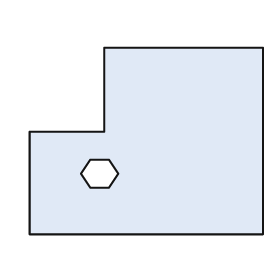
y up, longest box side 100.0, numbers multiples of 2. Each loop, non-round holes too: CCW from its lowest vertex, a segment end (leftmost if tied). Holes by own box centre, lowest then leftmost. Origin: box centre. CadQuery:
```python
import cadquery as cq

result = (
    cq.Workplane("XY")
    .moveTo(-50.0, -40.0)
    .lineTo(50.0, -40.0)
    .lineTo(50.0, 40.0)
    .lineTo(-18.0, 40.0)
    .lineTo(-18.0, 4.0)
    .lineTo(-50.0, 4.0)
    .close()
    .moveTo(-24.0, -20.0)
    .lineTo(-16.0, -20.0)
    .lineTo(-12.0, -14.0)
    .lineTo(-16.0, -8.0)
    .lineTo(-24.0, -8.0)
    .lineTo(-28.0, -14.0)
    .close()
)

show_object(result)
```